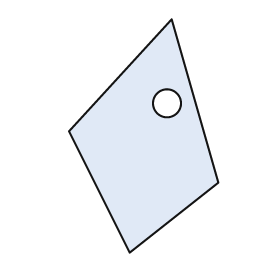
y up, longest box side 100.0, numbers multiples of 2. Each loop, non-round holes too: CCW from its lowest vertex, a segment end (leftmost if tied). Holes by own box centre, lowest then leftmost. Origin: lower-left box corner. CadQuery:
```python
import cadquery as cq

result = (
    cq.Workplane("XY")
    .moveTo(26.0, 0.0)
    .lineTo(64.0, 30.0)
    .lineTo(44.0, 100.0)
    .lineTo(0.0, 52.0)
    .close()
    .moveTo(42.0, 64.0)
    .circle(6.0)
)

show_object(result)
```